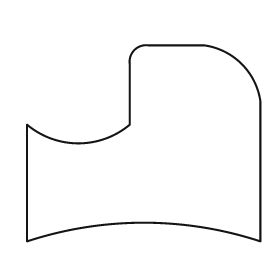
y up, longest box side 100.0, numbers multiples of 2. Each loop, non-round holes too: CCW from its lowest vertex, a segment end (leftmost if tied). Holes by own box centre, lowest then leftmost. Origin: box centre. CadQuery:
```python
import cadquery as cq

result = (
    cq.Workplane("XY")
    .moveTo(-50.0, -42.0)
    .threePointArc((0.0, -34.0), (50.0, -42.0))
    .lineTo(50.0, 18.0)
    .threePointArc((42.0, 34.0), (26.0, 42.0))
    .lineTo(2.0, 42.0)
    .threePointArc((-4.0, 40.0), (-6.0, 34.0))
    .lineTo(-6.0, 8.0)
    .threePointArc((-28.0, 0.0), (-50.0, 8.0))
    .close()
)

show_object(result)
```